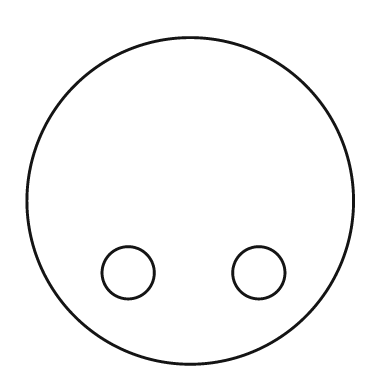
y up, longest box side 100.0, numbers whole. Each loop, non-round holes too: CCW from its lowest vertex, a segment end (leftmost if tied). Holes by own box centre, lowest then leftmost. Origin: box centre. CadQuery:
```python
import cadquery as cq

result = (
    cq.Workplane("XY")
    .moveTo(0.0, 0.0)
    .circle(50.0)
    .moveTo(-19.0, -22.0)
    .circle(8.0)
    .moveTo(21.0, -22.0)
    .circle(8.0)
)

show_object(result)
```